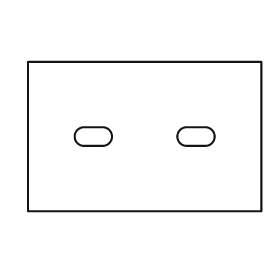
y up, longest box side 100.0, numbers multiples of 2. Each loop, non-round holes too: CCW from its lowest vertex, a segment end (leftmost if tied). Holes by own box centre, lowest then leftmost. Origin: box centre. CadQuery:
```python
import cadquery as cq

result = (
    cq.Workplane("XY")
    .moveTo(-50.0, -32.0)
    .lineTo(50.0, -32.0)
    .lineTo(50.0, 32.0)
    .lineTo(-50.0, 32.0)
    .close()
    .moveTo(-26.0, -4.0)
    .lineTo(-18.0, -4.0)
    .threePointArc((-14.0, 0.0), (-18.0, 4.0))
    .lineTo(-26.0, 4.0)
    .threePointArc((-30.0, 0.0), (-26.0, -4.0))
    .close()
    .moveTo(18.0, -4.0)
    .lineTo(26.0, -4.0)
    .threePointArc((30.0, 0.0), (26.0, 4.0))
    .lineTo(18.0, 4.0)
    .threePointArc((14.0, 0.0), (18.0, -4.0))
    .close()
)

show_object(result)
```